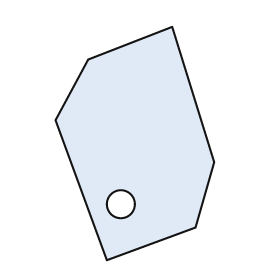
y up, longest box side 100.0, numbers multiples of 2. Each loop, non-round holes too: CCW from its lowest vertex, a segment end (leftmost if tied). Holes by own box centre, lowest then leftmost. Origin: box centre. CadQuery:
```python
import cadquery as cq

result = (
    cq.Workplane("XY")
    .moveTo(-12.0, -50.0)
    .lineTo(26.0, -36.0)
    .lineTo(34.0, -8.0)
    .lineTo(16.0, 50.0)
    .lineTo(-20.0, 36.0)
    .lineTo(-34.0, 10.0)
    .close()
    .moveTo(-6.0, -26.0)
    .circle(6.0)
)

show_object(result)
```